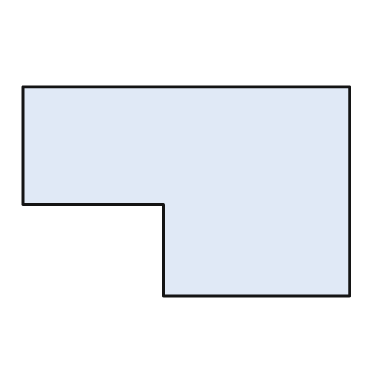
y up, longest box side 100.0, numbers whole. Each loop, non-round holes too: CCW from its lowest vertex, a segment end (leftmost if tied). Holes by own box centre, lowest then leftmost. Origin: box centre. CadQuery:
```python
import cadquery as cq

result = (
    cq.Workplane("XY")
    .moveTo(-7.0, -32.0)
    .lineTo(50.0, -32.0)
    .lineTo(50.0, 32.0)
    .lineTo(-50.0, 32.0)
    .lineTo(-50.0, -4.0)
    .lineTo(-7.0, -4.0)
    .close()
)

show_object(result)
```